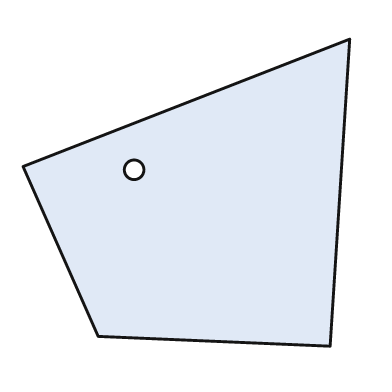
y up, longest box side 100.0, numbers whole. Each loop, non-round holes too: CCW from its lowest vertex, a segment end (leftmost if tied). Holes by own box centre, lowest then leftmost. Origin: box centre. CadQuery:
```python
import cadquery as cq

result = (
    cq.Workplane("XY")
    .moveTo(44.0, -47.0)
    .lineTo(50.0, 47.0)
    .lineTo(-50.0, 8.0)
    .lineTo(-27.0, -44.0)
    .close()
    .moveTo(-16.0, 7.0)
    .circle(3.0)
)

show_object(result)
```